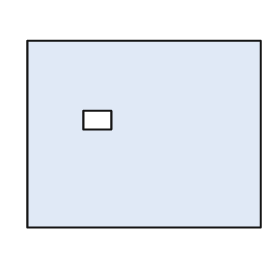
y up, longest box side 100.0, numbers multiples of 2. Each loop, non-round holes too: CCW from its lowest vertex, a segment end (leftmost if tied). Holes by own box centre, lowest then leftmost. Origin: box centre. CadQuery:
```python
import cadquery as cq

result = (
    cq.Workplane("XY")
    .moveTo(-50.0, -40.0)
    .lineTo(50.0, -40.0)
    .lineTo(50.0, 40.0)
    .lineTo(-50.0, 40.0)
    .close()
    .moveTo(-26.0, 2.0)
    .lineTo(-14.0, 2.0)
    .lineTo(-14.0, 10.0)
    .lineTo(-26.0, 10.0)
    .close()
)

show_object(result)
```